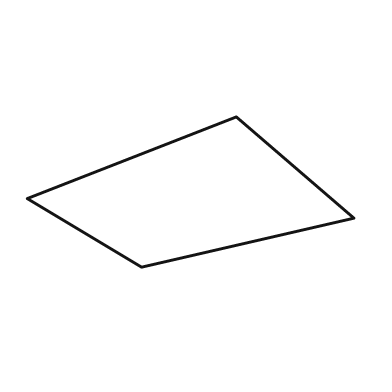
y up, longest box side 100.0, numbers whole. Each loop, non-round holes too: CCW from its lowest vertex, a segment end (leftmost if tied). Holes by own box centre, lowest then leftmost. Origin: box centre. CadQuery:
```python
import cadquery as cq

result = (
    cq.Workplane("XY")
    .moveTo(-15.0, -23.0)
    .lineTo(50.0, -8.0)
    .lineTo(14.0, 23.0)
    .lineTo(-50.0, -2.0)
    .close()
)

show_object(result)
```